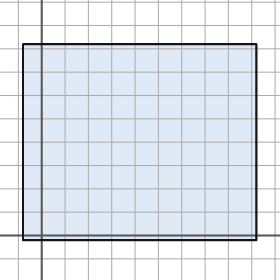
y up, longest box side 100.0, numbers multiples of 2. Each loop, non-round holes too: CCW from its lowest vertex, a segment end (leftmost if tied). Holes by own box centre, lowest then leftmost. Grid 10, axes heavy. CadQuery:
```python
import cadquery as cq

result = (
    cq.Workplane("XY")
    .moveTo(-8.0, -2.0)
    .lineTo(92.0, -2.0)
    .lineTo(92.0, 82.0)
    .lineTo(-8.0, 82.0)
    .close()
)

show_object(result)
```